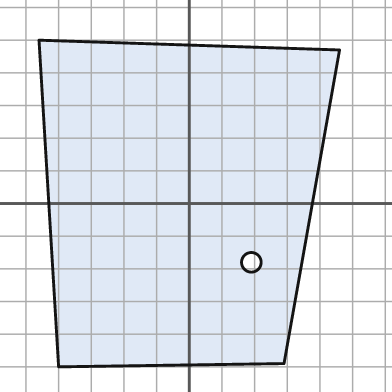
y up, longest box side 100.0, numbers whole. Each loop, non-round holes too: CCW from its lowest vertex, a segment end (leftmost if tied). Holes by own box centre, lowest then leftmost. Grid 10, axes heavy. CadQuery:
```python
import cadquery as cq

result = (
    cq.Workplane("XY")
    .moveTo(-40.0, -50.0)
    .lineTo(29.0, -49.0)
    .lineTo(46.0, 47.0)
    .lineTo(-46.0, 50.0)
    .close()
    .moveTo(19.0, -18.0)
    .circle(3.0)
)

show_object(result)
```